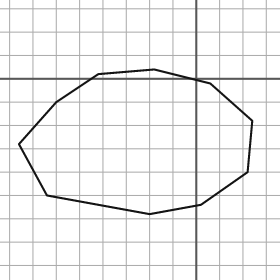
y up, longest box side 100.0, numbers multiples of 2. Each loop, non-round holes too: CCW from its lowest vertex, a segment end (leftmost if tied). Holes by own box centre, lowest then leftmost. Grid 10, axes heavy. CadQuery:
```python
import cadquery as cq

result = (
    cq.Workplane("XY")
    .moveTo(-20.0, -58.0)
    .lineTo(2.0, -54.0)
    .lineTo(22.0, -40.0)
    .lineTo(24.0, -18.0)
    .lineTo(6.0, -2.0)
    .lineTo(-18.0, 4.0)
    .lineTo(-42.0, 2.0)
    .lineTo(-60.0, -10.0)
    .lineTo(-76.0, -28.0)
    .lineTo(-64.0, -50.0)
    .close()
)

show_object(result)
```